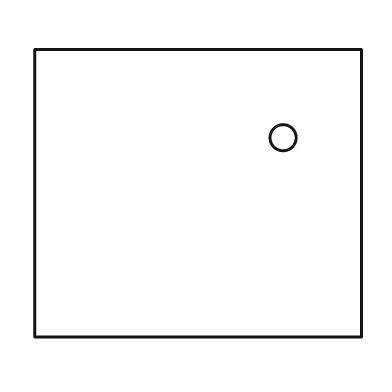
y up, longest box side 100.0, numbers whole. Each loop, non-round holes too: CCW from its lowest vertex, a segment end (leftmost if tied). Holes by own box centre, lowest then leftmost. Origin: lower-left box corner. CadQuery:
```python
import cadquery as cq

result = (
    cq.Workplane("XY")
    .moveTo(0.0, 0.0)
    .lineTo(100.0, 0.0)
    .lineTo(100.0, 88.0)
    .lineTo(0.0, 88.0)
    .close()
    .moveTo(76.0, 61.0)
    .circle(4.0)
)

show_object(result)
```